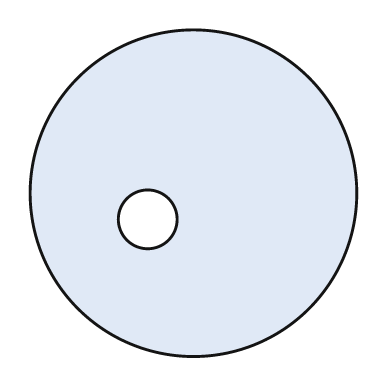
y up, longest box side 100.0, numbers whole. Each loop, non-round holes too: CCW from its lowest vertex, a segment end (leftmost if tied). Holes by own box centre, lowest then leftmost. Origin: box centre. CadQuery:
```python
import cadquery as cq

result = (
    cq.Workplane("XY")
    .moveTo(0.0, 0.0)
    .circle(50.0)
    .moveTo(-14.0, -8.0)
    .circle(9.0)
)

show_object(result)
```